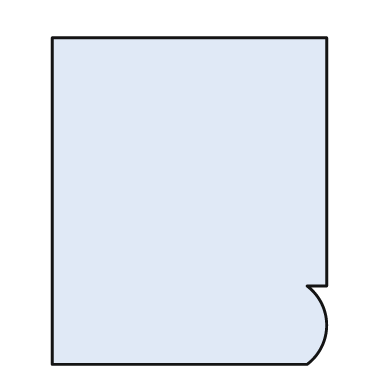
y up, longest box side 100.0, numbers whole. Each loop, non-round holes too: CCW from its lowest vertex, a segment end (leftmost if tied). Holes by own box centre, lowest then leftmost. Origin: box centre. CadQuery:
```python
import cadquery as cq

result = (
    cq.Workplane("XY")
    .moveTo(-42.0, -50.0)
    .lineTo(36.0, -50.0)
    .threePointArc((42.0, -38.0), (36.0, -26.0))
    .lineTo(42.0, -26.0)
    .lineTo(42.0, 50.0)
    .lineTo(-42.0, 50.0)
    .close()
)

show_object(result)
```